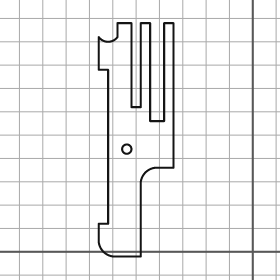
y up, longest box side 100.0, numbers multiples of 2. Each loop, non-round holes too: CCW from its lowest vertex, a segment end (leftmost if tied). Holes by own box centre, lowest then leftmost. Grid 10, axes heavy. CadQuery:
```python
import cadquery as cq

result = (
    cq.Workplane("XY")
    .moveTo(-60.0, -2.0)
    .lineTo(-48.0, -2.0)
    .lineTo(-48.0, 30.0)
    .threePointArc((-46.0, 34.0), (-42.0, 36.0))
    .lineTo(-34.0, 36.0)
    .lineTo(-34.0, 98.0)
    .lineTo(-38.0, 98.0)
    .lineTo(-38.0, 56.0)
    .lineTo(-44.0, 56.0)
    .lineTo(-44.0, 98.0)
    .lineTo(-48.0, 98.0)
    .lineTo(-48.0, 62.0)
    .lineTo(-52.0, 62.0)
    .lineTo(-52.0, 98.0)
    .lineTo(-58.0, 98.0)
    .lineTo(-58.0, 92.0)
    .threePointArc((-62.0, 90.0), (-66.0, 92.0))
    .lineTo(-66.0, 78.0)
    .lineTo(-62.0, 78.0)
    .lineTo(-62.0, 12.0)
    .lineTo(-66.0, 12.0)
    .lineTo(-66.0, 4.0)
    .threePointArc((-64.0, 0.0), (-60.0, -2.0))
    .close()
    .moveTo(-54.0, 44.0)
    .circle(2.0)
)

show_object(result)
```